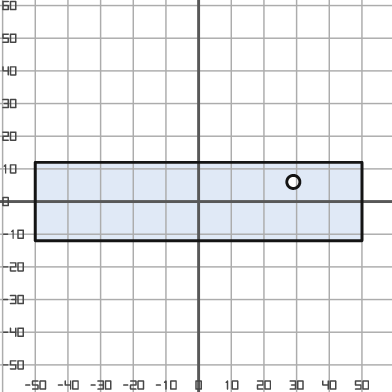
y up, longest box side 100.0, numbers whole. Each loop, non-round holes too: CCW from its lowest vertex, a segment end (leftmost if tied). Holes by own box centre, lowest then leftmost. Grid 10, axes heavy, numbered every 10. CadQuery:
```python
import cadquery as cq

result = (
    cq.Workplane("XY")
    .moveTo(-50.0, -12.0)
    .lineTo(50.0, -12.0)
    .lineTo(50.0, 12.0)
    .lineTo(-50.0, 12.0)
    .close()
    .moveTo(29.0, 6.0)
    .circle(2.0)
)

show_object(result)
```